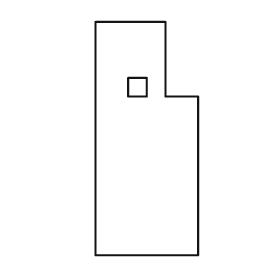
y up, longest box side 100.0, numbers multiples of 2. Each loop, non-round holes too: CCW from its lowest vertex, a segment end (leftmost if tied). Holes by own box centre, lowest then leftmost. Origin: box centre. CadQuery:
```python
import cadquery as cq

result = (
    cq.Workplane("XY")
    .moveTo(-22.0, -50.0)
    .lineTo(22.0, -50.0)
    .lineTo(22.0, 18.0)
    .lineTo(8.0, 18.0)
    .lineTo(8.0, 50.0)
    .lineTo(-22.0, 50.0)
    .close()
    .moveTo(-8.0, 18.0)
    .lineTo(0.0, 18.0)
    .lineTo(0.0, 26.0)
    .lineTo(-8.0, 26.0)
    .close()
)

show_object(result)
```